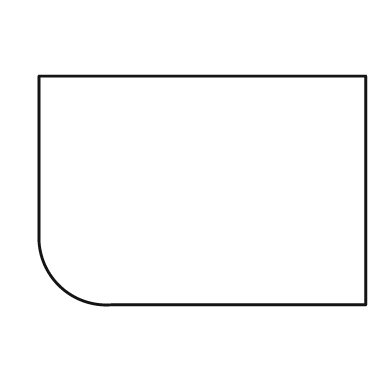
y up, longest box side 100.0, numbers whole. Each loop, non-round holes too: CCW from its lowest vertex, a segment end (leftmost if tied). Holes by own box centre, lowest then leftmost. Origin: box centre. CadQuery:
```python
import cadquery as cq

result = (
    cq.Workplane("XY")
    .moveTo(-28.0, -35.0)
    .lineTo(50.0, -35.0)
    .lineTo(50.0, 35.0)
    .lineTo(-50.0, 35.0)
    .lineTo(-50.0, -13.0)
    .threePointArc((-44.0, -29.0), (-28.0, -35.0))
    .close()
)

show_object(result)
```